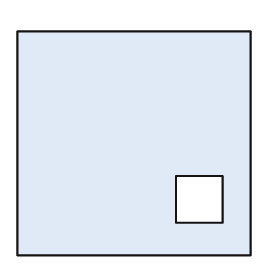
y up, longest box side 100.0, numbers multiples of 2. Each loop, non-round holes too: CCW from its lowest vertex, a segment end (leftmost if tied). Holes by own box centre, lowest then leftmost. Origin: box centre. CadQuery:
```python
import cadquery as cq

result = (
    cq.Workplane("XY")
    .moveTo(-50.0, -48.0)
    .lineTo(50.0, -48.0)
    .lineTo(50.0, 48.0)
    .lineTo(-50.0, 48.0)
    .close()
    .moveTo(18.0, -34.0)
    .lineTo(38.0, -34.0)
    .lineTo(38.0, -14.0)
    .lineTo(18.0, -14.0)
    .close()
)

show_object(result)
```